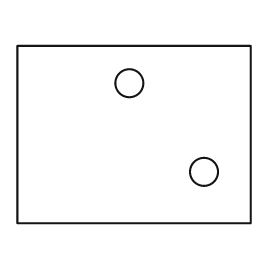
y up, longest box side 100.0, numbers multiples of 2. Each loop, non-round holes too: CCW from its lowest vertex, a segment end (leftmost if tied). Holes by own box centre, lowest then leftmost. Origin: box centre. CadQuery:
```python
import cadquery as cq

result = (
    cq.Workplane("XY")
    .moveTo(-50.0, -38.0)
    .lineTo(50.0, -38.0)
    .lineTo(50.0, 38.0)
    .lineTo(-50.0, 38.0)
    .close()
    .moveTo(30.0, -16.0)
    .circle(6.0)
    .moveTo(-2.0, 22.0)
    .circle(6.0)
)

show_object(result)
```